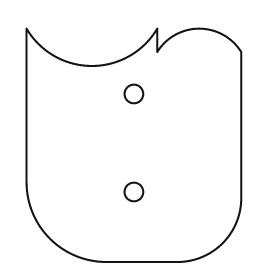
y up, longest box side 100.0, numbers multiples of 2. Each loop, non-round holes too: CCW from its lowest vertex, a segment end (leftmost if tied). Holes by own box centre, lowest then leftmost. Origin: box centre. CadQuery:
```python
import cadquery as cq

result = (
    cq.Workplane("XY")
    .moveTo(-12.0, -50.0)
    .lineTo(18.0, -50.0)
    .threePointArc((38.0, -42.0), (46.0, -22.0))
    .lineTo(46.0, 40.0)
    .threePointArc((28.0, 50.0), (10.0, 40.0))
    .lineTo(10.0, 50.0)
    .threePointArc((-18.0, 34.0), (-46.0, 50.0))
    .lineTo(-46.0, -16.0)
    .threePointArc((-36.0, -40.0), (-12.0, -50.0))
    .close()
    .moveTo(0.0, -20.0)
    .circle(4.0)
    .moveTo(0.0, 22.0)
    .circle(4.0)
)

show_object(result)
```